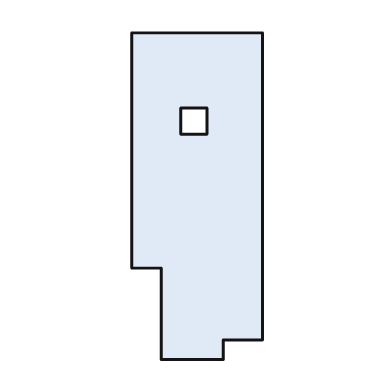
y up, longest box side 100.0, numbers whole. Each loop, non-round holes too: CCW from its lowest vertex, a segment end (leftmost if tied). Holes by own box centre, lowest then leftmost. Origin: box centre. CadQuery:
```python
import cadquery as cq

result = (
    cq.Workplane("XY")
    .moveTo(-11.0, -50.0)
    .lineTo(8.0, -50.0)
    .lineTo(8.0, -44.0)
    .lineTo(20.0, -44.0)
    .lineTo(20.0, 50.0)
    .lineTo(-20.0, 50.0)
    .lineTo(-20.0, -22.0)
    .lineTo(-11.0, -22.0)
    .close()
    .moveTo(-5.0, 19.0)
    .lineTo(3.0, 19.0)
    .lineTo(3.0, 27.0)
    .lineTo(-5.0, 27.0)
    .close()
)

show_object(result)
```